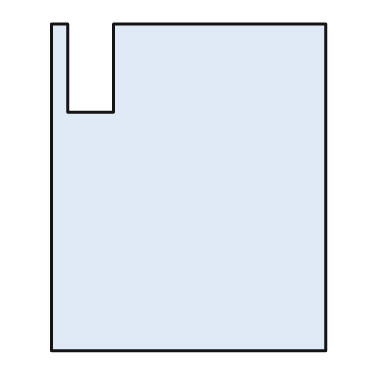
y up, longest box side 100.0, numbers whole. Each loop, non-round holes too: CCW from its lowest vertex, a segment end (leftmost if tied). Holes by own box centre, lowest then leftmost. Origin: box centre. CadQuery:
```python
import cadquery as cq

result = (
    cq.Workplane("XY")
    .moveTo(-42.0, -50.0)
    .lineTo(42.0, -50.0)
    .lineTo(42.0, 50.0)
    .lineTo(-23.0, 50.0)
    .lineTo(-23.0, 23.0)
    .lineTo(-37.0, 23.0)
    .lineTo(-37.0, 50.0)
    .lineTo(-42.0, 50.0)
    .close()
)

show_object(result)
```